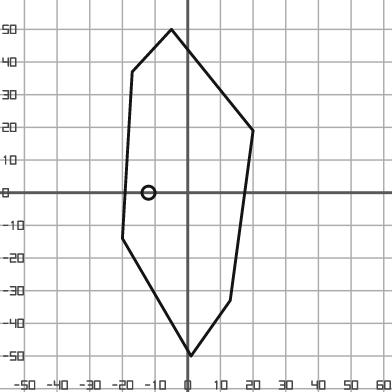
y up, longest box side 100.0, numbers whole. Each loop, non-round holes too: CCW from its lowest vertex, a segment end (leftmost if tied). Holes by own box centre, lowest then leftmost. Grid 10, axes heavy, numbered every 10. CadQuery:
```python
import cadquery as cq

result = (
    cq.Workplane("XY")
    .moveTo(1.0, -50.0)
    .lineTo(13.0, -33.0)
    .lineTo(20.0, 19.0)
    .lineTo(-5.0, 50.0)
    .lineTo(-17.0, 37.0)
    .lineTo(-20.0, -14.0)
    .close()
    .moveTo(-12.0, 0.0)
    .circle(2.0)
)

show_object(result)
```